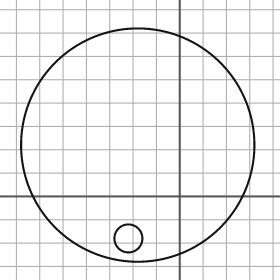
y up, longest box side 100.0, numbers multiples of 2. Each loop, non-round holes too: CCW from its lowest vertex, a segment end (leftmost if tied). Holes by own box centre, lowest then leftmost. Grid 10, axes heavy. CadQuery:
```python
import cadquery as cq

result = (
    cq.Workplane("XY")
    .moveTo(-18.0, 22.0)
    .circle(50.0)
    .moveTo(-22.0, -18.0)
    .circle(6.0)
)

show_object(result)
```